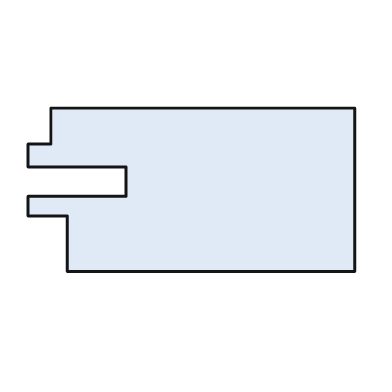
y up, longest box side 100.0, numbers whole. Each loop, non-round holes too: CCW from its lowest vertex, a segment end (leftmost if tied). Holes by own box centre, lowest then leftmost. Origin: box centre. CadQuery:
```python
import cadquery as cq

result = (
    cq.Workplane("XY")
    .moveTo(-38.0, -25.0)
    .lineTo(50.0, -25.0)
    .lineTo(50.0, 25.0)
    .lineTo(-43.0, 25.0)
    .lineTo(-43.0, 14.0)
    .lineTo(-50.0, 14.0)
    .lineTo(-50.0, 7.0)
    .lineTo(-20.0, 7.0)
    .lineTo(-20.0, -2.0)
    .lineTo(-50.0, -2.0)
    .lineTo(-50.0, -8.0)
    .lineTo(-38.0, -8.0)
    .close()
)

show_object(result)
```